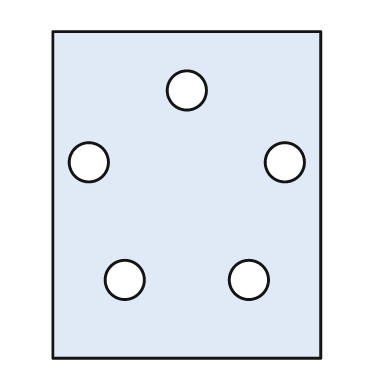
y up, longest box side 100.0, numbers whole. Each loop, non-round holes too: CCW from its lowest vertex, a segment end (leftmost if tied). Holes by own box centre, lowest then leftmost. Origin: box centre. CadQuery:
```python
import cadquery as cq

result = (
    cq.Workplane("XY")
    .moveTo(-41.0, -50.0)
    .lineTo(41.0, -50.0)
    .lineTo(41.0, 50.0)
    .lineTo(-41.0, 50.0)
    .close()
    .moveTo(-19.0, -26.0)
    .circle(6.0)
    .moveTo(19.0, -26.0)
    .circle(6.0)
    .moveTo(-30.0, 10.0)
    .circle(6.0)
    .moveTo(30.0, 10.0)
    .circle(6.0)
    .moveTo(0.0, 32.0)
    .circle(6.0)
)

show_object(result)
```